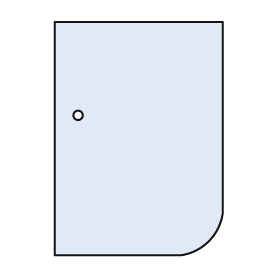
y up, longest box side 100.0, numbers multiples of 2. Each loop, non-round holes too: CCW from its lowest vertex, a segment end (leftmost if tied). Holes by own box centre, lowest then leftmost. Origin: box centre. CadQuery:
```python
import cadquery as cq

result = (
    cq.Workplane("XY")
    .moveTo(-36.0, -50.0)
    .lineTo(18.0, -50.0)
    .threePointArc((30.0, -44.0), (36.0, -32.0))
    .lineTo(36.0, 50.0)
    .lineTo(-36.0, 50.0)
    .close()
    .moveTo(-26.0, 10.0)
    .circle(2.0)
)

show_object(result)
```